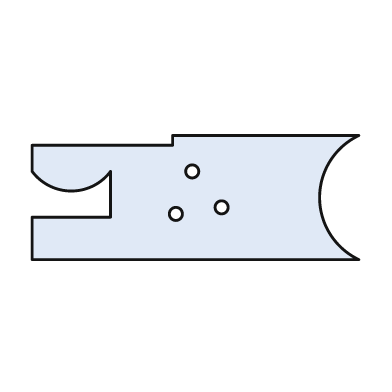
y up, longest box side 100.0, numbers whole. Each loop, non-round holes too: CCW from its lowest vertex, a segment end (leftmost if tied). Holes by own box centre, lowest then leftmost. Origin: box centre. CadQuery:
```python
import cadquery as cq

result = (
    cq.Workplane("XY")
    .moveTo(-50.0, -19.0)
    .lineTo(50.0, -19.0)
    .threePointArc((38.0, 0.0), (50.0, 19.0))
    .lineTo(-7.0, 19.0)
    .lineTo(-7.0, 16.0)
    .lineTo(-50.0, 16.0)
    .lineTo(-50.0, 8.0)
    .threePointArc((-38.0, 2.0), (-26.0, 8.0))
    .lineTo(-26.0, -6.0)
    .lineTo(-50.0, -6.0)
    .close()
    .moveTo(-6.0, -5.0)
    .circle(2.0)
    .moveTo(8.0, -3.0)
    .circle(2.0)
    .moveTo(-1.0, 8.0)
    .circle(2.0)
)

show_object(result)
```